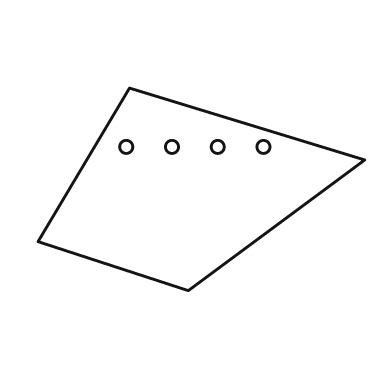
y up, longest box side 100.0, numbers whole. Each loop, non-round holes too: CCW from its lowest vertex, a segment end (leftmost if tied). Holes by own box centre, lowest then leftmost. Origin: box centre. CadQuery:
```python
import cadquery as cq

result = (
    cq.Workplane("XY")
    .moveTo(-4.0, -31.0)
    .lineTo(50.0, 9.0)
    .lineTo(-22.0, 31.0)
    .lineTo(-50.0, -16.0)
    .close()
    .moveTo(-23.0, 13.0)
    .circle(2.0)
    .moveTo(-9.0, 13.0)
    .circle(2.0)
    .moveTo(5.0, 13.0)
    .circle(2.0)
    .moveTo(19.0, 13.0)
    .circle(2.0)
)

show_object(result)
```